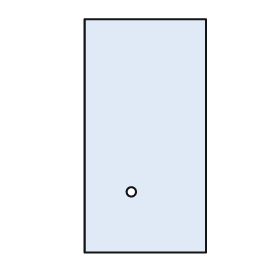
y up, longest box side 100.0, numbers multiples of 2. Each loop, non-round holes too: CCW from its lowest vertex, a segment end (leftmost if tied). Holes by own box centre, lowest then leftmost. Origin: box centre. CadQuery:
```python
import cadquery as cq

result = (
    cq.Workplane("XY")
    .moveTo(-26.0, -50.0)
    .lineTo(26.0, -50.0)
    .lineTo(26.0, 50.0)
    .lineTo(-26.0, 50.0)
    .close()
    .moveTo(-6.0, -24.0)
    .circle(2.0)
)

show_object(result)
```